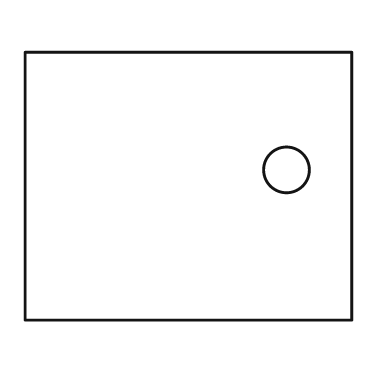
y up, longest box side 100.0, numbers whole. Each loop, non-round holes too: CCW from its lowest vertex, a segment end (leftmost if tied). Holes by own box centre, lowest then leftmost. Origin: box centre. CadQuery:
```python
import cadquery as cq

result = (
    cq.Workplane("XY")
    .moveTo(-50.0, -41.0)
    .lineTo(50.0, -41.0)
    .lineTo(50.0, 41.0)
    .lineTo(-50.0, 41.0)
    .close()
    .moveTo(30.0, 5.0)
    .circle(7.0)
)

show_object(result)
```